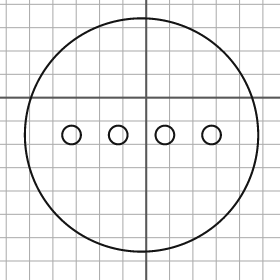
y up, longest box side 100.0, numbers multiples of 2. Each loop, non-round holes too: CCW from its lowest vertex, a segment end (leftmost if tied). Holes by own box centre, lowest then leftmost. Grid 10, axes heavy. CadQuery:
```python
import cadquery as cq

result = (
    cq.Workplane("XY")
    .moveTo(-2.0, -16.0)
    .circle(50.0)
    .moveTo(-32.0, -16.0)
    .circle(4.0)
    .moveTo(-12.0, -16.0)
    .circle(4.0)
    .moveTo(8.0, -16.0)
    .circle(4.0)
    .moveTo(28.0, -16.0)
    .circle(4.0)
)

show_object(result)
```